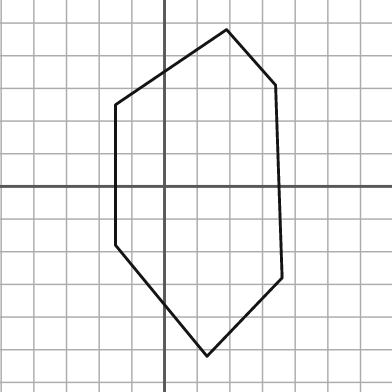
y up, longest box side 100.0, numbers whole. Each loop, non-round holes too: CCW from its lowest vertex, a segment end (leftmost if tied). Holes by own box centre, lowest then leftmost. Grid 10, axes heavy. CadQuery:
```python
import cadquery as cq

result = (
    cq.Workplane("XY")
    .moveTo(13.0, -52.0)
    .lineTo(36.0, -28.0)
    .lineTo(34.0, 31.0)
    .lineTo(19.0, 48.0)
    .lineTo(-15.0, 25.0)
    .lineTo(-15.0, -18.0)
    .close()
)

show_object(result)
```